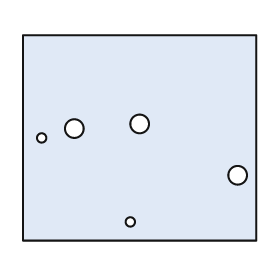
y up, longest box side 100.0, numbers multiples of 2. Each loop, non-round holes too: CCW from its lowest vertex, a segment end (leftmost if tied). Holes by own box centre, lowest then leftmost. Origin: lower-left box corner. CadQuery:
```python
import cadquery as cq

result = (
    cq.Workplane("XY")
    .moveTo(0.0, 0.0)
    .lineTo(100.0, 0.0)
    .lineTo(100.0, 88.0)
    .lineTo(0.0, 88.0)
    .close()
    .moveTo(46.0, 8.0)
    .circle(2.0)
    .moveTo(92.0, 28.0)
    .circle(4.0)
    .moveTo(8.0, 44.0)
    .circle(2.0)
    .moveTo(22.0, 48.0)
    .circle(4.0)
    .moveTo(50.0, 50.0)
    .circle(4.0)
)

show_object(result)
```